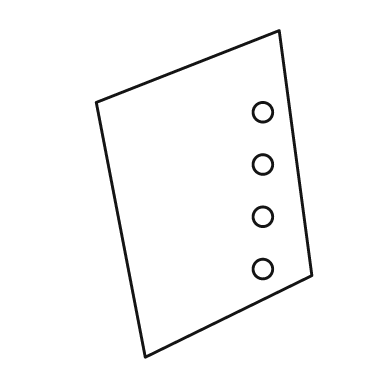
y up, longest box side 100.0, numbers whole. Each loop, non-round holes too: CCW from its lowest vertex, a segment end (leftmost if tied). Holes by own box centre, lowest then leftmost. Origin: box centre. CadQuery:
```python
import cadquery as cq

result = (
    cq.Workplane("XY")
    .moveTo(-18.0, -50.0)
    .lineTo(33.0, -25.0)
    .lineTo(23.0, 50.0)
    .lineTo(-33.0, 28.0)
    .close()
    .moveTo(18.0, -23.0)
    .circle(3.0)
    .moveTo(18.0, -7.0)
    .circle(3.0)
    .moveTo(18.0, 9.0)
    .circle(3.0)
    .moveTo(18.0, 25.0)
    .circle(3.0)
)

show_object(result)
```